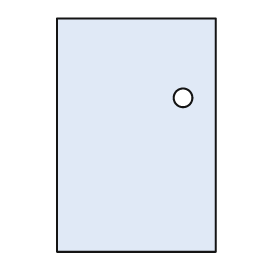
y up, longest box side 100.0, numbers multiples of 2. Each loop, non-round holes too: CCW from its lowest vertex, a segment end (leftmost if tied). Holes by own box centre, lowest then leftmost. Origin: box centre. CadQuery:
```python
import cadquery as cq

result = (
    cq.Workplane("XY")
    .moveTo(-34.0, -50.0)
    .lineTo(34.0, -50.0)
    .lineTo(34.0, 50.0)
    .lineTo(-34.0, 50.0)
    .close()
    .moveTo(20.0, 16.0)
    .circle(4.0)
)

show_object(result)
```